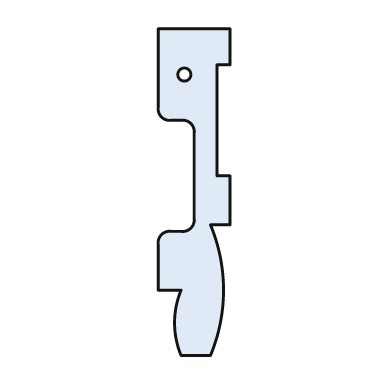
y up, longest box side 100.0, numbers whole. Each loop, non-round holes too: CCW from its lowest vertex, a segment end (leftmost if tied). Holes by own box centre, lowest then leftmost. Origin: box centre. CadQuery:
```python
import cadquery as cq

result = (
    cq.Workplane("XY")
    .moveTo(-4.0, -50.0)
    .lineTo(5.0, -50.0)
    .threePointArc((9.0, -30.0), (5.0, -10.0))
    .lineTo(11.0, -10.0)
    .lineTo(11.0, 5.0)
    .lineTo(7.0, 5.0)
    .lineTo(7.0, 39.0)
    .lineTo(11.0, 39.0)
    .lineTo(11.0, 50.0)
    .lineTo(-11.0, 50.0)
    .lineTo(-11.0, 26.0)
    .threePointArc((-10.0, 23.0), (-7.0, 22.0))
    .lineTo(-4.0, 22.0)
    .threePointArc((-1.0, 21.0), (0.0, 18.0))
    .lineTo(0.0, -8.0)
    .threePointArc((-1.0, -11.0), (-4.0, -12.0))
    .lineTo(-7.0, -12.0)
    .threePointArc((-10.0, -13.0), (-11.0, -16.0))
    .lineTo(-11.0, -30.0)
    .lineTo(-4.0, -30.0)
    .threePointArc((-6.0, -40.0), (-4.0, -50.0))
    .close()
    .moveTo(-3.0, 36.0)
    .circle(2.0)
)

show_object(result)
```